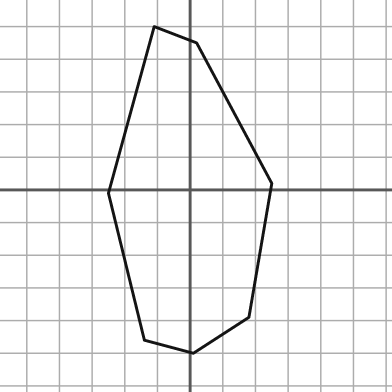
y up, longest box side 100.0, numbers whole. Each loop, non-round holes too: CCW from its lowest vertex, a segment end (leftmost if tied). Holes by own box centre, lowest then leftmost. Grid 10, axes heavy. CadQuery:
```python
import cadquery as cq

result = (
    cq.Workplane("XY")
    .moveTo(1.0, -50.0)
    .lineTo(18.0, -39.0)
    .lineTo(25.0, 2.0)
    .lineTo(2.0, 45.0)
    .lineTo(-11.0, 50.0)
    .lineTo(-25.0, -1.0)
    .lineTo(-14.0, -46.0)
    .close()
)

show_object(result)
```